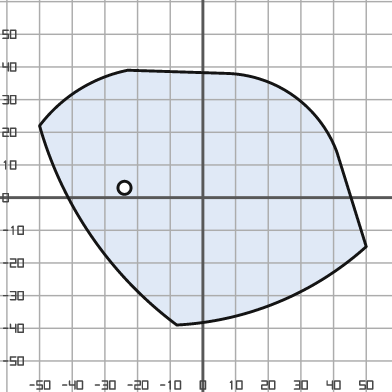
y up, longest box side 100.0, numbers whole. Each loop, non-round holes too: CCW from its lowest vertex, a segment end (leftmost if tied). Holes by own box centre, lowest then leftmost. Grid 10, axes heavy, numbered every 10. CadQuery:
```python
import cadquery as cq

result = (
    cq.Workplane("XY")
    .moveTo(-8.0, -39.0)
    .threePointArc((23.0, -32.0), (50.0, -15.0))
    .lineTo(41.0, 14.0)
    .threePointArc((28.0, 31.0), (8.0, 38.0))
    .lineTo(-23.0, 39.0)
    .threePointArc((-38.0, 33.0), (-50.0, 22.0))
    .threePointArc((-34.0, -12.0), (-8.0, -39.0))
    .close()
    .moveTo(-24.0, 3.0)
    .circle(2.0)
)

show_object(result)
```